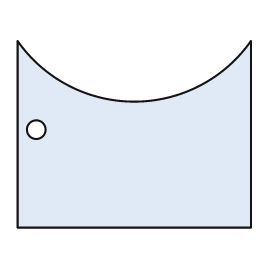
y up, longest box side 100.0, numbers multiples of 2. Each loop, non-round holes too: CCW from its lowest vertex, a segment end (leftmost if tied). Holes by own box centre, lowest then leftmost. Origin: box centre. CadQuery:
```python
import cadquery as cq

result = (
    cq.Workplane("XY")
    .moveTo(-50.0, -40.0)
    .lineTo(50.0, -40.0)
    .lineTo(50.0, 40.0)
    .threePointArc((0.0, 14.0), (-50.0, 40.0))
    .close()
    .moveTo(-42.0, 2.0)
    .circle(4.0)
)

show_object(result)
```